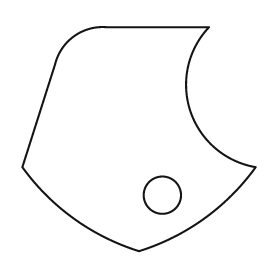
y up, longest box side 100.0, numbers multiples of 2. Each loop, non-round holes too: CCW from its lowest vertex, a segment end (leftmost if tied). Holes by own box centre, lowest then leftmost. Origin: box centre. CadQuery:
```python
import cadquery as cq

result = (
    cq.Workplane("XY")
    .moveTo(0.0, -48.0)
    .threePointArc((28.0, -34.0), (50.0, -12.0))
    .threePointArc((22.0, 12.0), (30.0, 48.0))
    .lineTo(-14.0, 48.0)
    .threePointArc((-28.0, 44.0), (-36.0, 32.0))
    .lineTo(-50.0, -12.0)
    .threePointArc((-28.0, -34.0), (0.0, -48.0))
    .close()
    .moveTo(10.0, -24.0)
    .circle(8.0)
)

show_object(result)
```